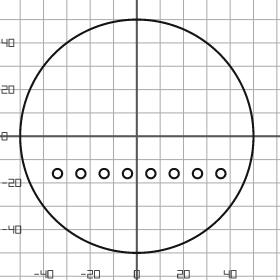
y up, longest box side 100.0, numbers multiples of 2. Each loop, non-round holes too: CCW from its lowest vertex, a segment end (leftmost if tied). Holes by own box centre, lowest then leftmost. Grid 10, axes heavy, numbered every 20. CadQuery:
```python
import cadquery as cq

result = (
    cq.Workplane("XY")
    .moveTo(0.0, 0.0)
    .circle(50.0)
    .moveTo(-34.0, -16.0)
    .circle(2.0)
    .moveTo(-24.0, -16.0)
    .circle(2.0)
    .moveTo(-14.0, -16.0)
    .circle(2.0)
    .moveTo(-4.0, -16.0)
    .circle(2.0)
    .moveTo(6.0, -16.0)
    .circle(2.0)
    .moveTo(16.0, -16.0)
    .circle(2.0)
    .moveTo(26.0, -16.0)
    .circle(2.0)
    .moveTo(36.0, -16.0)
    .circle(2.0)
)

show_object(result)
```